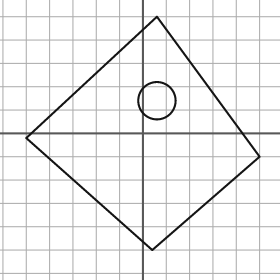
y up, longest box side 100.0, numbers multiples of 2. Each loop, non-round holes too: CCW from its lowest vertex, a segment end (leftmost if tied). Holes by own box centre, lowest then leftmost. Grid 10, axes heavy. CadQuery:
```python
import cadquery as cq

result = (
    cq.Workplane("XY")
    .moveTo(4.0, -50.0)
    .lineTo(50.0, -10.0)
    .lineTo(6.0, 50.0)
    .lineTo(-50.0, -2.0)
    .close()
    .moveTo(6.0, 14.0)
    .circle(8.0)
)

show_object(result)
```